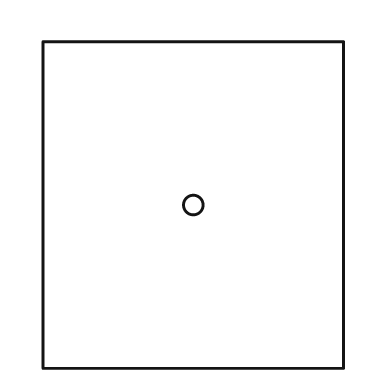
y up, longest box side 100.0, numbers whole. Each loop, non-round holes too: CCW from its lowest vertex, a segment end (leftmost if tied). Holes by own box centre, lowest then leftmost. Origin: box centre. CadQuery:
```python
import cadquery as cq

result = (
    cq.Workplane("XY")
    .moveTo(-46.0, -50.0)
    .lineTo(46.0, -50.0)
    .lineTo(46.0, 50.0)
    .lineTo(-46.0, 50.0)
    .close()
    .moveTo(0.0, 0.0)
    .circle(3.0)
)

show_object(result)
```